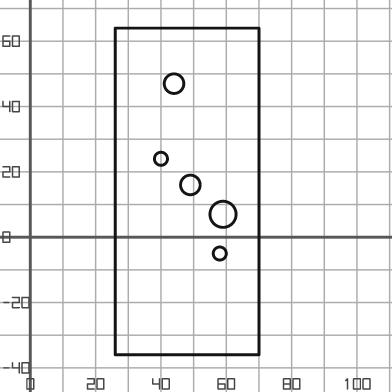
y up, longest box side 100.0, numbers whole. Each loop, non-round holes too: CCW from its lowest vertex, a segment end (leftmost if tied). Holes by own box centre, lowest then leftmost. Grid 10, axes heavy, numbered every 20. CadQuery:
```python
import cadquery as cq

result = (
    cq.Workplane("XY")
    .moveTo(26.0, -36.0)
    .lineTo(70.0, -36.0)
    .lineTo(70.0, 64.0)
    .lineTo(26.0, 64.0)
    .close()
    .moveTo(58.0, -5.0)
    .circle(2.0)
    .moveTo(59.0, 7.0)
    .circle(4.0)
    .moveTo(49.0, 16.0)
    .circle(3.0)
    .moveTo(40.0, 24.0)
    .circle(2.0)
    .moveTo(44.0, 47.0)
    .circle(3.0)
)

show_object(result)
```